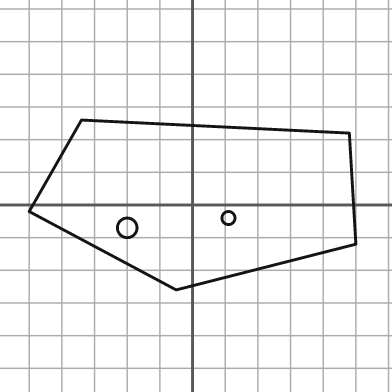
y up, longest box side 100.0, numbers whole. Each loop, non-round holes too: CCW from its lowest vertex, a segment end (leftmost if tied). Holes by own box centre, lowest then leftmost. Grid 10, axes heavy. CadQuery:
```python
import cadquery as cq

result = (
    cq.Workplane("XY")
    .moveTo(-5.0, -26.0)
    .lineTo(50.0, -12.0)
    .lineTo(48.0, 22.0)
    .lineTo(-34.0, 26.0)
    .lineTo(-50.0, -2.0)
    .close()
    .moveTo(-20.0, -7.0)
    .circle(3.0)
    .moveTo(11.0, -4.0)
    .circle(2.0)
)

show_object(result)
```